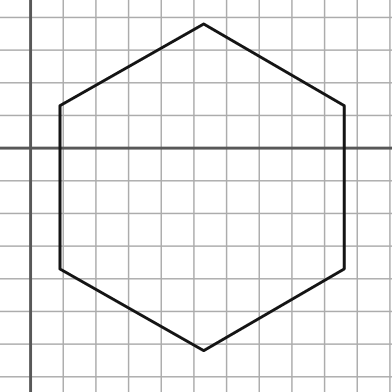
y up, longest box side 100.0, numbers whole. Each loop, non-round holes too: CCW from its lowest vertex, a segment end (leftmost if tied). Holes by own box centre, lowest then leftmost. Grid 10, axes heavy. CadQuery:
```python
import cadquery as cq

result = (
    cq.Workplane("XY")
    .moveTo(53.0, -62.0)
    .lineTo(96.0, -37.0)
    .lineTo(96.0, 13.0)
    .lineTo(53.0, 38.0)
    .lineTo(9.0, 13.0)
    .lineTo(9.0, -37.0)
    .close()
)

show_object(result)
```